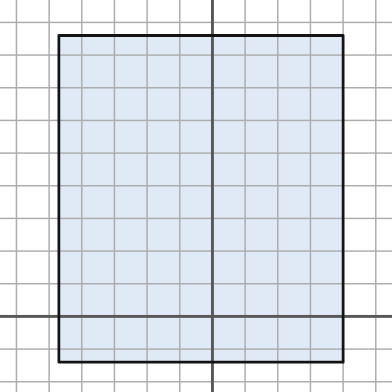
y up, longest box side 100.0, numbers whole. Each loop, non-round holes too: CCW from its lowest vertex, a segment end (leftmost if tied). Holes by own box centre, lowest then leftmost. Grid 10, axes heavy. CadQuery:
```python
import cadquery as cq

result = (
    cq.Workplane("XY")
    .moveTo(-47.0, -14.0)
    .lineTo(40.0, -14.0)
    .lineTo(40.0, 86.0)
    .lineTo(-47.0, 86.0)
    .close()
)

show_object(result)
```